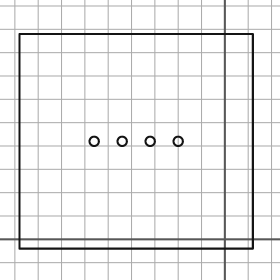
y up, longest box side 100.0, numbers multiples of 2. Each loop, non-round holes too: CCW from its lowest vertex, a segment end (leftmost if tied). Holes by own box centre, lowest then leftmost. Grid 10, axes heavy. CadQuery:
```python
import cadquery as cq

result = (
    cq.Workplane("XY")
    .moveTo(-88.0, -4.0)
    .lineTo(12.0, -4.0)
    .lineTo(12.0, 88.0)
    .lineTo(-88.0, 88.0)
    .close()
    .moveTo(-56.0, 42.0)
    .circle(2.0)
    .moveTo(-44.0, 42.0)
    .circle(2.0)
    .moveTo(-32.0, 42.0)
    .circle(2.0)
    .moveTo(-20.0, 42.0)
    .circle(2.0)
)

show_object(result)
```